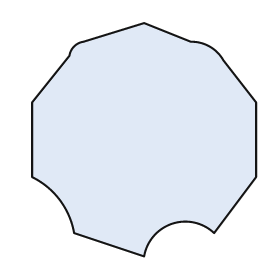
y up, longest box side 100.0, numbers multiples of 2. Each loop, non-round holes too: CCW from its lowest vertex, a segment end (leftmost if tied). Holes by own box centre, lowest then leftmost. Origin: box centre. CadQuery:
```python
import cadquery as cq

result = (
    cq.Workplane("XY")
    .moveTo(0.0, -50.0)
    .threePointArc((12.0, -36.0), (30.0, -40.0))
    .lineTo(48.0, -16.0)
    .lineTo(48.0, 16.0)
    .lineTo(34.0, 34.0)
    .threePointArc((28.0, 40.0), (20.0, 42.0))
    .lineTo(0.0, 50.0)
    .lineTo(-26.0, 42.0)
    .threePointArc((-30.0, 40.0), (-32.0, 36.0))
    .lineTo(-48.0, 16.0)
    .lineTo(-48.0, -16.0)
    .threePointArc((-36.0, -26.0), (-30.0, -40.0))
    .close()
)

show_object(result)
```